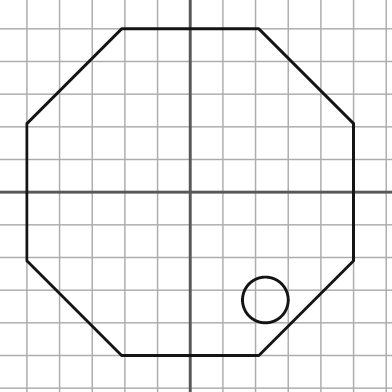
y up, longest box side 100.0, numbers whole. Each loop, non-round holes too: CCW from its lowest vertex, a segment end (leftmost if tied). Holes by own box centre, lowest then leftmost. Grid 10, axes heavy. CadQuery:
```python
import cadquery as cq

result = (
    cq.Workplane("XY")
    .moveTo(-21.0, -50.0)
    .lineTo(21.0, -50.0)
    .lineTo(50.0, -21.0)
    .lineTo(50.0, 21.0)
    .lineTo(21.0, 50.0)
    .lineTo(-21.0, 50.0)
    .lineTo(-50.0, 21.0)
    .lineTo(-50.0, -21.0)
    .close()
    .moveTo(23.0, -33.0)
    .circle(7.0)
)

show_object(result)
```